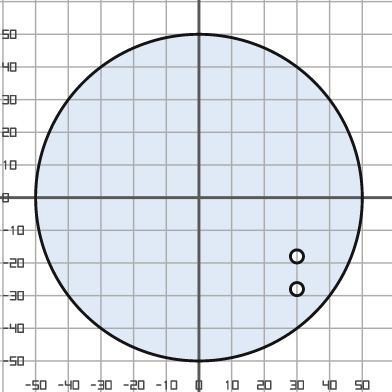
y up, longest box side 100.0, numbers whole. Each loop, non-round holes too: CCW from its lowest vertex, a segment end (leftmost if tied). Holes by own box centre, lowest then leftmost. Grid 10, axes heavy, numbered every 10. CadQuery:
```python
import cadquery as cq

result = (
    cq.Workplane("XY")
    .moveTo(0.0, 0.0)
    .circle(50.0)
    .moveTo(30.0, -28.0)
    .circle(2.0)
    .moveTo(30.0, -18.0)
    .circle(2.0)
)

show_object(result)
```